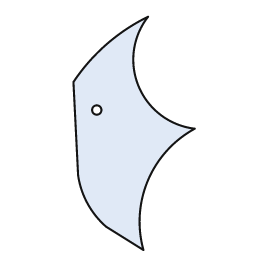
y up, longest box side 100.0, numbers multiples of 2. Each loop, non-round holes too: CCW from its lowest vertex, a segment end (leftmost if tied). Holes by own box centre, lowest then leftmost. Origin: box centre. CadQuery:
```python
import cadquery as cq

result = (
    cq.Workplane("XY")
    .moveTo(4.0, -50.0)
    .threePointArc((6.0, -20.0), (26.0, 2.0))
    .threePointArc((2.0, 20.0), (6.0, 50.0))
    .threePointArc((-12.0, 38.0), (-26.0, 22.0))
    .lineTo(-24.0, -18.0)
    .threePointArc((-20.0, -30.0), (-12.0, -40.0))
    .close()
    .moveTo(-16.0, 10.0)
    .circle(2.0)
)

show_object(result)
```